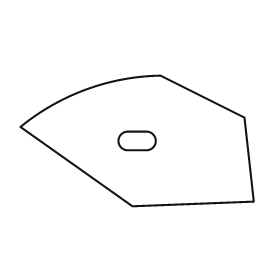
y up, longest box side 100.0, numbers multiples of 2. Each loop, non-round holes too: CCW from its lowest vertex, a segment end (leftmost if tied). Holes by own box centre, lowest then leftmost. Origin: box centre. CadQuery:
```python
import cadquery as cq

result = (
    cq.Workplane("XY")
    .moveTo(-2.0, -28.0)
    .lineTo(50.0, -26.0)
    .lineTo(46.0, 10.0)
    .lineTo(10.0, 28.0)
    .threePointArc((-22.0, 22.0), (-50.0, 6.0))
    .close()
    .moveTo(-4.0, -4.0)
    .lineTo(4.0, -4.0)
    .threePointArc((8.0, 0.0), (4.0, 4.0))
    .lineTo(-4.0, 4.0)
    .threePointArc((-8.0, 0.0), (-4.0, -4.0))
    .close()
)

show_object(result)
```